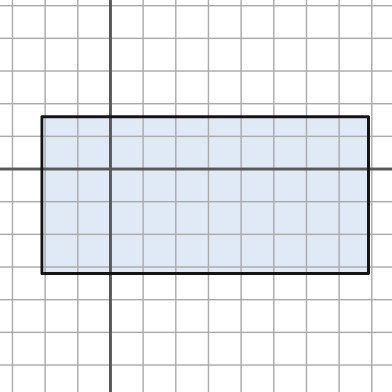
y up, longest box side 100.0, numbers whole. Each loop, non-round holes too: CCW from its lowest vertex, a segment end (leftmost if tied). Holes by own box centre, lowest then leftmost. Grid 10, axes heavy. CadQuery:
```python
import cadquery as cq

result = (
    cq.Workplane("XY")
    .moveTo(-21.0, -32.0)
    .lineTo(79.0, -32.0)
    .lineTo(79.0, 16.0)
    .lineTo(-21.0, 16.0)
    .close()
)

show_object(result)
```